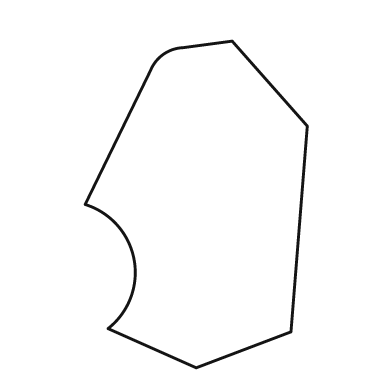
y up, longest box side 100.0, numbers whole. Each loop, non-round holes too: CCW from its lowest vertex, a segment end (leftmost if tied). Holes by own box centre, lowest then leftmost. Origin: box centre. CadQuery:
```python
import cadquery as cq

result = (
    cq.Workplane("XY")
    .moveTo(0.0, -50.0)
    .lineTo(29.0, -39.0)
    .lineTo(34.0, 24.0)
    .lineTo(11.0, 50.0)
    .lineTo(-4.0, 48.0)
    .threePointArc((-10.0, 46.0), (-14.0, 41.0))
    .lineTo(-34.0, 0.0)
    .threePointArc((-19.0, -17.0), (-27.0, -38.0))
    .close()
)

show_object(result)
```